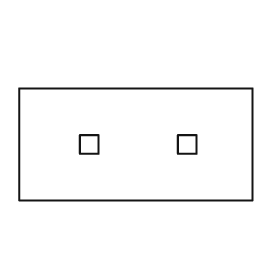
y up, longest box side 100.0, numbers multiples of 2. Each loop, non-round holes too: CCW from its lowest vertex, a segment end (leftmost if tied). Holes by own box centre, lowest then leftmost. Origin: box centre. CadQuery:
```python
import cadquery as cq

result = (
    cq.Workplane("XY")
    .moveTo(-50.0, -24.0)
    .lineTo(50.0, -24.0)
    .lineTo(50.0, 24.0)
    .lineTo(-50.0, 24.0)
    .close()
    .moveTo(-24.0, -4.0)
    .lineTo(-16.0, -4.0)
    .lineTo(-16.0, 4.0)
    .lineTo(-24.0, 4.0)
    .close()
    .moveTo(18.0, -4.0)
    .lineTo(26.0, -4.0)
    .lineTo(26.0, 4.0)
    .lineTo(18.0, 4.0)
    .close()
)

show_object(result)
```